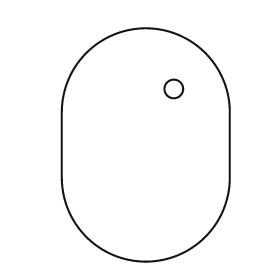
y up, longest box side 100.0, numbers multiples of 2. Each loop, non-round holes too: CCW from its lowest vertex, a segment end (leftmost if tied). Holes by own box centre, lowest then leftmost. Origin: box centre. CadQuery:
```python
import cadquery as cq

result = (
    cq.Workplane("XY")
    .moveTo(-36.0, -14.0)
    .threePointArc((0.0, -50.0), (36.0, -14.0))
    .lineTo(36.0, 14.0)
    .threePointArc((0.0, 50.0), (-36.0, 14.0))
    .close()
    .moveTo(12.0, 24.0)
    .circle(4.0)
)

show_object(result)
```